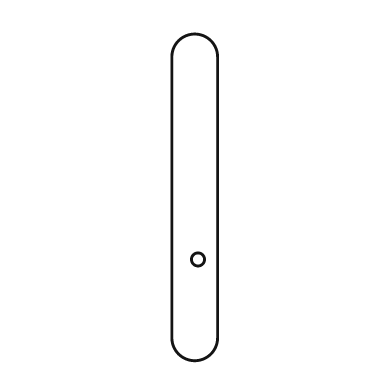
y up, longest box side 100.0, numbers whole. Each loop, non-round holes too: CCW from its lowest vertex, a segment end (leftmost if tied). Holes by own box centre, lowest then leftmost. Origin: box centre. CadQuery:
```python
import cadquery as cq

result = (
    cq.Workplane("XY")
    .moveTo(-7.0, -43.0)
    .threePointArc((0.0, -50.0), (7.0, -43.0))
    .lineTo(7.0, 43.0)
    .threePointArc((0.0, 50.0), (-7.0, 43.0))
    .close()
    .moveTo(1.0, -19.0)
    .circle(2.0)
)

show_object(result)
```